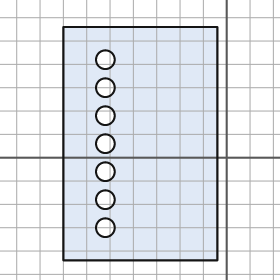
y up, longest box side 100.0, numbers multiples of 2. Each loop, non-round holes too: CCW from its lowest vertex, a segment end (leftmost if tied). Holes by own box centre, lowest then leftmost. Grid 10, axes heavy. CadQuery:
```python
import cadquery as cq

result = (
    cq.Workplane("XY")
    .moveTo(-70.0, -44.0)
    .lineTo(-4.0, -44.0)
    .lineTo(-4.0, 56.0)
    .lineTo(-70.0, 56.0)
    .close()
    .moveTo(-52.0, -30.0)
    .circle(4.0)
    .moveTo(-52.0, -18.0)
    .circle(4.0)
    .moveTo(-52.0, -6.0)
    .circle(4.0)
    .moveTo(-52.0, 6.0)
    .circle(4.0)
    .moveTo(-52.0, 18.0)
    .circle(4.0)
    .moveTo(-52.0, 30.0)
    .circle(4.0)
    .moveTo(-52.0, 42.0)
    .circle(4.0)
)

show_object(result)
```